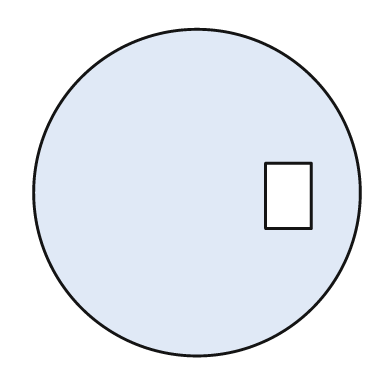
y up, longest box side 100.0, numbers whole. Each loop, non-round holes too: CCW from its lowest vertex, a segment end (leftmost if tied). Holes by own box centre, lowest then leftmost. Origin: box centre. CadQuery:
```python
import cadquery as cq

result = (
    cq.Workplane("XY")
    .moveTo(0.0, 0.0)
    .circle(50.0)
    .moveTo(21.0, -11.0)
    .lineTo(35.0, -11.0)
    .lineTo(35.0, 9.0)
    .lineTo(21.0, 9.0)
    .close()
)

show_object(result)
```